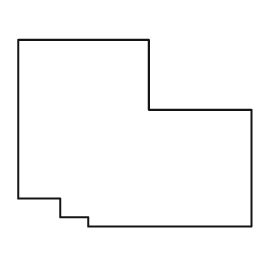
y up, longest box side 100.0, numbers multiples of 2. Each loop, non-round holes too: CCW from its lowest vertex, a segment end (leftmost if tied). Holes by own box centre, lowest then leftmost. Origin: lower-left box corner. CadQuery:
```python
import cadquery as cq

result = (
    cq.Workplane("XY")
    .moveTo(30.0, 0.0)
    .lineTo(100.0, 0.0)
    .lineTo(100.0, 50.0)
    .lineTo(56.0, 50.0)
    .lineTo(56.0, 80.0)
    .lineTo(0.0, 80.0)
    .lineTo(0.0, 12.0)
    .lineTo(18.0, 12.0)
    .lineTo(18.0, 4.0)
    .lineTo(30.0, 4.0)
    .close()
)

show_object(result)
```